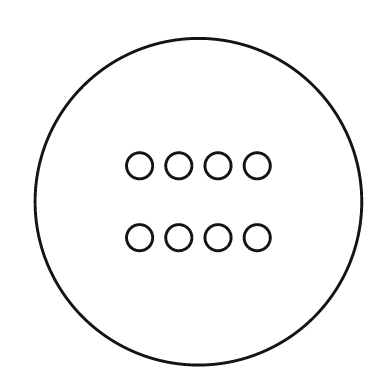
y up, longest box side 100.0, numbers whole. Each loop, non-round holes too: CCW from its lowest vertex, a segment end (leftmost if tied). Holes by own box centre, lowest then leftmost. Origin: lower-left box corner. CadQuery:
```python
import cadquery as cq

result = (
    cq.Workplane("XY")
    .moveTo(50.0, 50.0)
    .circle(50.0)
    .moveTo(32.0, 39.0)
    .circle(4.0)
    .moveTo(44.0, 39.0)
    .circle(4.0)
    .moveTo(56.0, 39.0)
    .circle(4.0)
    .moveTo(68.0, 39.0)
    .circle(4.0)
    .moveTo(32.0, 61.0)
    .circle(4.0)
    .moveTo(44.0, 61.0)
    .circle(4.0)
    .moveTo(56.0, 61.0)
    .circle(4.0)
    .moveTo(68.0, 61.0)
    .circle(4.0)
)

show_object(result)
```